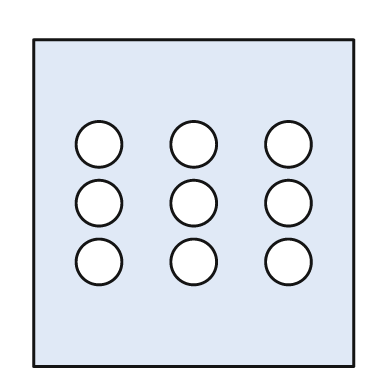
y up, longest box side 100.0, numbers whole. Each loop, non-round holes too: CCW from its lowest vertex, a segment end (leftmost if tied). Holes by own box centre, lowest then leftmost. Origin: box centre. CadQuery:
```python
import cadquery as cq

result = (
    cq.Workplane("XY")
    .moveTo(-49.0, -50.0)
    .lineTo(49.0, -50.0)
    .lineTo(49.0, 50.0)
    .lineTo(-49.0, 50.0)
    .close()
    .moveTo(-29.0, -18.0)
    .circle(7.0)
    .moveTo(0.0, -18.0)
    .circle(7.0)
    .moveTo(29.0, -18.0)
    .circle(7.0)
    .moveTo(-29.0, 0.0)
    .circle(7.0)
    .moveTo(0.0, 0.0)
    .circle(7.0)
    .moveTo(29.0, 0.0)
    .circle(7.0)
    .moveTo(-29.0, 18.0)
    .circle(7.0)
    .moveTo(0.0, 18.0)
    .circle(7.0)
    .moveTo(29.0, 18.0)
    .circle(7.0)
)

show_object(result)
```